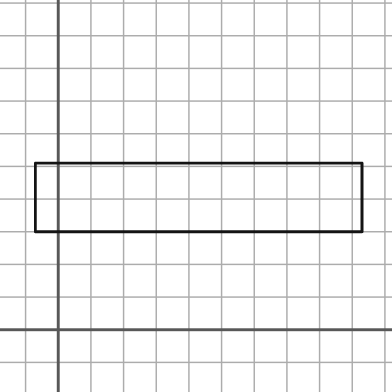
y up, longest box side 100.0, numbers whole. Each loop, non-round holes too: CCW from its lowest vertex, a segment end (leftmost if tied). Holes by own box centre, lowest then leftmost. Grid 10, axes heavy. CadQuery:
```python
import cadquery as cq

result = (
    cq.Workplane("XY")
    .moveTo(-7.0, 30.0)
    .lineTo(93.0, 30.0)
    .lineTo(93.0, 51.0)
    .lineTo(-7.0, 51.0)
    .close()
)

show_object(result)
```